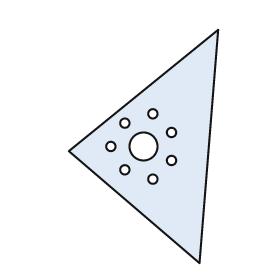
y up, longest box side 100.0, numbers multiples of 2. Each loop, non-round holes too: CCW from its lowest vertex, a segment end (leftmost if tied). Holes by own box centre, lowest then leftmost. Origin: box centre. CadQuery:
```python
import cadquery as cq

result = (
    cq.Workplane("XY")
    .moveTo(24.0, -50.0)
    .lineTo(32.0, 50.0)
    .lineTo(-32.0, -2.0)
    .close()
    .moveTo(4.0, -14.0)
    .circle(2.0)
    .moveTo(-8.0, -10.0)
    .circle(2.0)
    .moveTo(12.0, -6.0)
    .circle(2.0)
    .moveTo(-14.0, 0.0)
    .circle(2.0)
    .moveTo(0.0, 0.0)
    .circle(6.0)
    .moveTo(12.0, 6.0)
    .circle(2.0)
    .moveTo(-8.0, 10.0)
    .circle(2.0)
    .moveTo(4.0, 14.0)
    .circle(2.0)
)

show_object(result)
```